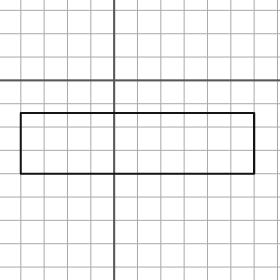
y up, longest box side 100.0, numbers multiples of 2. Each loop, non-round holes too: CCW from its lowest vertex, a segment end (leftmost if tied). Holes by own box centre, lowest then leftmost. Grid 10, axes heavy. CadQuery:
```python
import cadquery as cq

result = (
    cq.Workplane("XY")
    .moveTo(-40.0, -40.0)
    .lineTo(60.0, -40.0)
    .lineTo(60.0, -14.0)
    .lineTo(-40.0, -14.0)
    .close()
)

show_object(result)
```